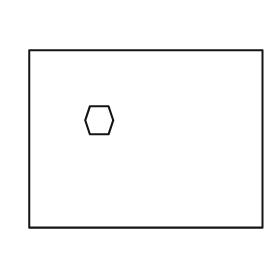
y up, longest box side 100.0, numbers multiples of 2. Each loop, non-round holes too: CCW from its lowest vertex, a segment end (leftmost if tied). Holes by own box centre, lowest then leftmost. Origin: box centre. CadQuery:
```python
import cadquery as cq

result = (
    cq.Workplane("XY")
    .moveTo(-50.0, -38.0)
    .lineTo(50.0, -38.0)
    .lineTo(50.0, 38.0)
    .lineTo(-50.0, 38.0)
    .close()
    .moveTo(-24.0, 2.0)
    .lineTo(-16.0, 2.0)
    .lineTo(-14.0, 8.0)
    .lineTo(-16.0, 14.0)
    .lineTo(-24.0, 14.0)
    .lineTo(-26.0, 8.0)
    .close()
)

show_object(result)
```